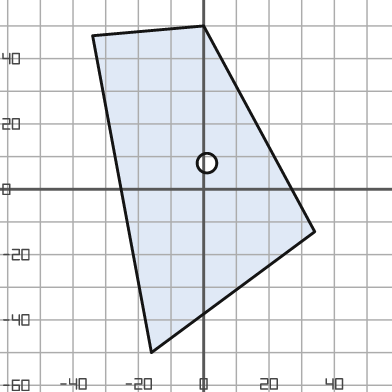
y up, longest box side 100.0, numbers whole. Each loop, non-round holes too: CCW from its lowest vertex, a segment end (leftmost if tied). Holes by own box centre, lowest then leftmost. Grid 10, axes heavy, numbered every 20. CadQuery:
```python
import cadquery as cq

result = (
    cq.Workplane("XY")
    .moveTo(-16.0, -50.0)
    .lineTo(34.0, -13.0)
    .lineTo(0.0, 50.0)
    .lineTo(-34.0, 47.0)
    .close()
    .moveTo(1.0, 8.0)
    .circle(3.0)
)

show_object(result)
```